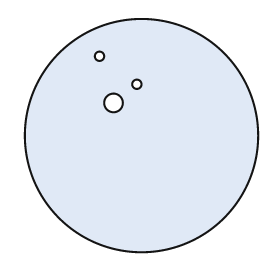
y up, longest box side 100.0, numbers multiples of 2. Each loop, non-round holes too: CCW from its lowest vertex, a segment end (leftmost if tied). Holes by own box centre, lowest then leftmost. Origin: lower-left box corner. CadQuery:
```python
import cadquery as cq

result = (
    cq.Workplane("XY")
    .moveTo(50.0, 50.0)
    .circle(50.0)
    .moveTo(38.0, 64.0)
    .circle(4.0)
    .moveTo(48.0, 72.0)
    .circle(2.0)
    .moveTo(32.0, 84.0)
    .circle(2.0)
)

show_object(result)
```